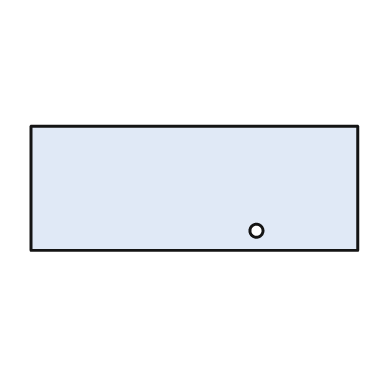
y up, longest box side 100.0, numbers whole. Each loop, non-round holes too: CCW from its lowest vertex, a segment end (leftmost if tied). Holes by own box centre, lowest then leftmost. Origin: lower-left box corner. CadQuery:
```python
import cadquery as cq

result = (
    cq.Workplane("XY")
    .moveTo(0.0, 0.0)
    .lineTo(100.0, 0.0)
    .lineTo(100.0, 38.0)
    .lineTo(0.0, 38.0)
    .close()
    .moveTo(69.0, 6.0)
    .circle(2.0)
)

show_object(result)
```